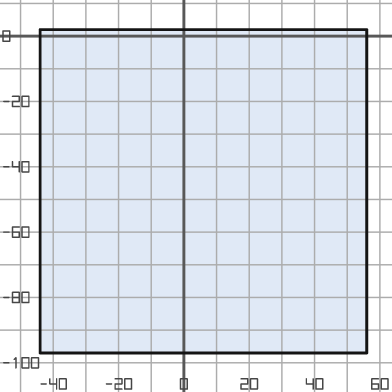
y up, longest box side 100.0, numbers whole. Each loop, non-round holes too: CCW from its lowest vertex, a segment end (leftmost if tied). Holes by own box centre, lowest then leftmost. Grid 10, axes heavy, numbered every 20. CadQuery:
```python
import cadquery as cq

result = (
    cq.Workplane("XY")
    .moveTo(-44.0, -97.0)
    .lineTo(56.0, -97.0)
    .lineTo(56.0, 2.0)
    .lineTo(-44.0, 2.0)
    .close()
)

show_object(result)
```